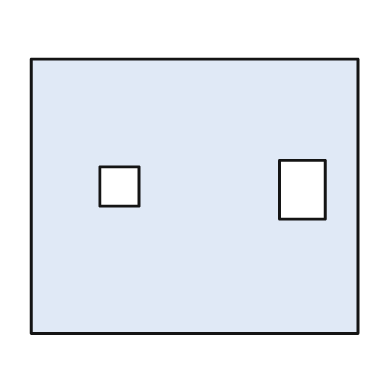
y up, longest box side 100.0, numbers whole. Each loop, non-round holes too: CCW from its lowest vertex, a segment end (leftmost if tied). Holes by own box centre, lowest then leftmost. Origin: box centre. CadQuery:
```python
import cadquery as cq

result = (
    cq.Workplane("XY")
    .moveTo(-50.0, -42.0)
    .lineTo(50.0, -42.0)
    .lineTo(50.0, 42.0)
    .lineTo(-50.0, 42.0)
    .close()
    .moveTo(26.0, -7.0)
    .lineTo(40.0, -7.0)
    .lineTo(40.0, 11.0)
    .lineTo(26.0, 11.0)
    .close()
    .moveTo(-29.0, -3.0)
    .lineTo(-17.0, -3.0)
    .lineTo(-17.0, 9.0)
    .lineTo(-29.0, 9.0)
    .close()
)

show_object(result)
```